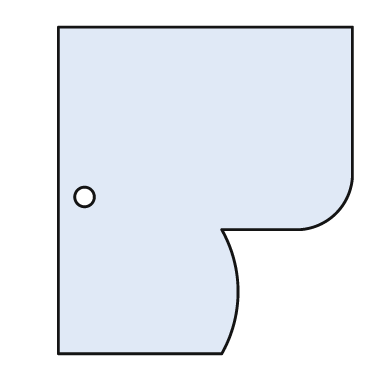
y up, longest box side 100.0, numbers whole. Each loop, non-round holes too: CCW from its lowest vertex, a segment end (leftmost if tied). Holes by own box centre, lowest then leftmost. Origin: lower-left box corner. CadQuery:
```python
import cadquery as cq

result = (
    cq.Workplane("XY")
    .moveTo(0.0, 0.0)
    .lineTo(50.0, 0.0)
    .threePointArc((55.0, 19.0), (50.0, 38.0))
    .lineTo(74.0, 38.0)
    .threePointArc((85.0, 43.0), (90.0, 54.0))
    .lineTo(90.0, 100.0)
    .lineTo(0.0, 100.0)
    .close()
    .moveTo(8.0, 48.0)
    .circle(3.0)
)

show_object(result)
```